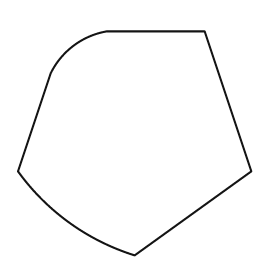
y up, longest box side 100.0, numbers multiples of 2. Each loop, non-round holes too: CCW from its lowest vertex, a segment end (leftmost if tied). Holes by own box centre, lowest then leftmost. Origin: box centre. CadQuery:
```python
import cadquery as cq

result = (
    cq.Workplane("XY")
    .moveTo(0.0, -48.0)
    .lineTo(50.0, -12.0)
    .lineTo(30.0, 48.0)
    .lineTo(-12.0, 48.0)
    .threePointArc((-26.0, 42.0), (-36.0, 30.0))
    .lineTo(-50.0, -12.0)
    .threePointArc((-28.0, -34.0), (0.0, -48.0))
    .close()
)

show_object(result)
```